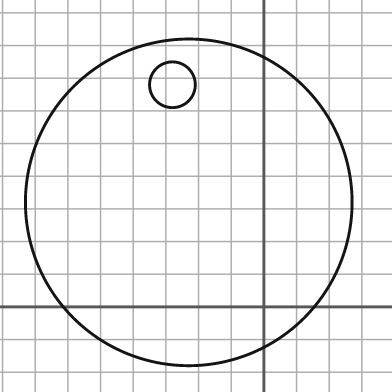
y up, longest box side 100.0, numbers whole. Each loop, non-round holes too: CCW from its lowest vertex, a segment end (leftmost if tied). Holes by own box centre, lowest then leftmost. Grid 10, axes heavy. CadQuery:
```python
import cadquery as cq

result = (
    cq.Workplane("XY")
    .moveTo(-23.0, 32.0)
    .circle(50.0)
    .moveTo(-28.0, 68.0)
    .circle(7.0)
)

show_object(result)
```